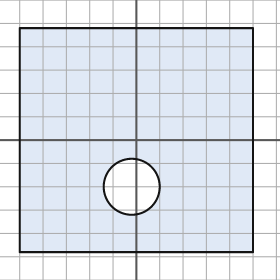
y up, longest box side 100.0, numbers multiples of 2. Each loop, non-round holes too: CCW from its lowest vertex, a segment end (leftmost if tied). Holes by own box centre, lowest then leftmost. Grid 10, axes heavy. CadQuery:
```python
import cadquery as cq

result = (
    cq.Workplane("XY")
    .moveTo(-50.0, -48.0)
    .lineTo(50.0, -48.0)
    .lineTo(50.0, 48.0)
    .lineTo(-50.0, 48.0)
    .close()
    .moveTo(-2.0, -20.0)
    .circle(12.0)
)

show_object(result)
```